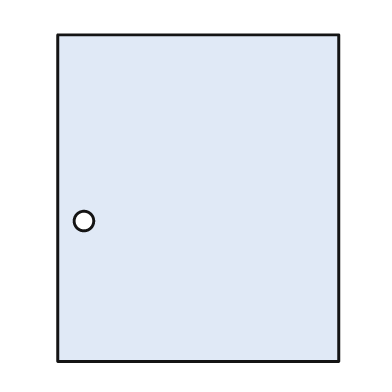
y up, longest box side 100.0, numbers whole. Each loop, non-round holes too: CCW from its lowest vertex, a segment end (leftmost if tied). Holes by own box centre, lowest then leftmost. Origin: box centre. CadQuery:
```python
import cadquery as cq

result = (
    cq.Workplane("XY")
    .moveTo(-43.0, -50.0)
    .lineTo(43.0, -50.0)
    .lineTo(43.0, 50.0)
    .lineTo(-43.0, 50.0)
    .close()
    .moveTo(-35.0, -7.0)
    .circle(3.0)
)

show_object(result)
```